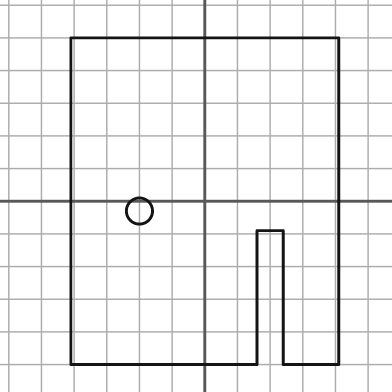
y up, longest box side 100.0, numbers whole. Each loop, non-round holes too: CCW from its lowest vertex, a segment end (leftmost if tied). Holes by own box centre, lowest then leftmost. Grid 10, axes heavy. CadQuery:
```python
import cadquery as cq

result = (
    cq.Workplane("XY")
    .moveTo(-41.0, -50.0)
    .lineTo(16.0, -50.0)
    .lineTo(16.0, -9.0)
    .lineTo(24.0, -9.0)
    .lineTo(24.0, -50.0)
    .lineTo(41.0, -50.0)
    .lineTo(41.0, 50.0)
    .lineTo(-41.0, 50.0)
    .close()
    .moveTo(-20.0, -3.0)
    .circle(4.0)
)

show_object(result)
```